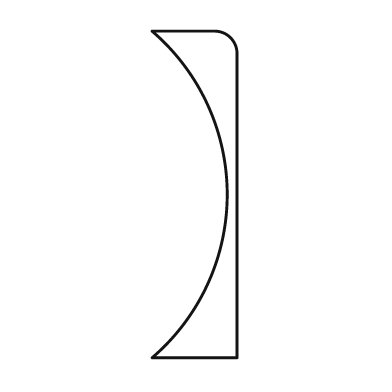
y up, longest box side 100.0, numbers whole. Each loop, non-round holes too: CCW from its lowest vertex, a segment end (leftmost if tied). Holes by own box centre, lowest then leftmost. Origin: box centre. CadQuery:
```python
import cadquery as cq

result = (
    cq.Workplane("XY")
    .moveTo(-13.0, -50.0)
    .lineTo(13.0, -50.0)
    .lineTo(13.0, 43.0)
    .threePointArc((11.0, 48.0), (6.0, 50.0))
    .lineTo(-13.0, 50.0)
    .threePointArc((10.0, 0.0), (-13.0, -50.0))
    .close()
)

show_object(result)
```